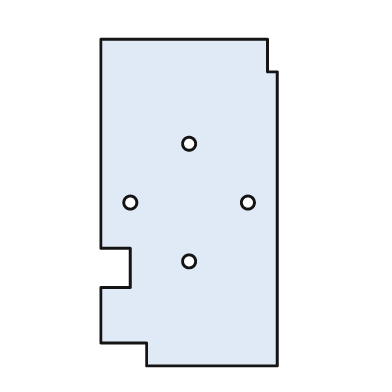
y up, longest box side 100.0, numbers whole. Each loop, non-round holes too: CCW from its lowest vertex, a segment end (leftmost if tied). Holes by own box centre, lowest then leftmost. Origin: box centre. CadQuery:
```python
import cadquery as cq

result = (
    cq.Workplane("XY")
    .moveTo(-13.0, -50.0)
    .lineTo(27.0, -50.0)
    .lineTo(27.0, 40.0)
    .lineTo(24.0, 40.0)
    .lineTo(24.0, 50.0)
    .lineTo(-27.0, 50.0)
    .lineTo(-27.0, -14.0)
    .lineTo(-18.0, -14.0)
    .lineTo(-18.0, -26.0)
    .lineTo(-27.0, -26.0)
    .lineTo(-27.0, -43.0)
    .lineTo(-13.0, -43.0)
    .close()
    .moveTo(0.0, -18.0)
    .circle(2.0)
    .moveTo(-18.0, 0.0)
    .circle(2.0)
    .moveTo(18.0, 0.0)
    .circle(2.0)
    .moveTo(0.0, 18.0)
    .circle(2.0)
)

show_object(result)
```